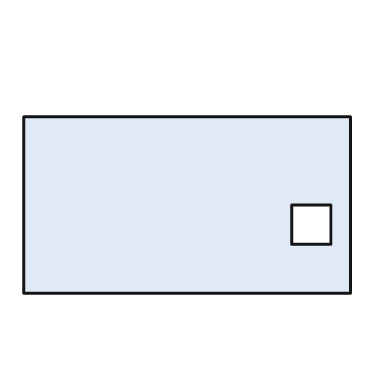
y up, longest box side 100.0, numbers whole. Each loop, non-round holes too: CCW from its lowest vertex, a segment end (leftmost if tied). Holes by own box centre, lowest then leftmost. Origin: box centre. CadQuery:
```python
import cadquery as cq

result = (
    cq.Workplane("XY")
    .moveTo(-50.0, -27.0)
    .lineTo(50.0, -27.0)
    .lineTo(50.0, 27.0)
    .lineTo(-50.0, 27.0)
    .close()
    .moveTo(32.0, -12.0)
    .lineTo(44.0, -12.0)
    .lineTo(44.0, 0.0)
    .lineTo(32.0, 0.0)
    .close()
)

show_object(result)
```